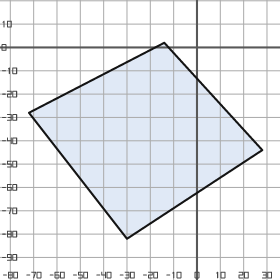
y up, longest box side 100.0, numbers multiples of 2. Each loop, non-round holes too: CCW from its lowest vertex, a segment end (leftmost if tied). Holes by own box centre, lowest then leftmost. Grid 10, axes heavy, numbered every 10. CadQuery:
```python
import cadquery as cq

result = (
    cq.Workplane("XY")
    .moveTo(-30.0, -82.0)
    .lineTo(28.0, -44.0)
    .lineTo(-14.0, 2.0)
    .lineTo(-72.0, -28.0)
    .close()
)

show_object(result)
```